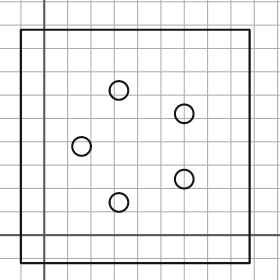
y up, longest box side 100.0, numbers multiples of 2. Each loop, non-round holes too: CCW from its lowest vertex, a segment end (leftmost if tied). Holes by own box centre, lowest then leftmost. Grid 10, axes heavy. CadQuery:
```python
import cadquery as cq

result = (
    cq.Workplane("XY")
    .moveTo(-10.0, -12.0)
    .lineTo(88.0, -12.0)
    .lineTo(88.0, 88.0)
    .lineTo(-10.0, 88.0)
    .close()
    .moveTo(32.0, 14.0)
    .circle(4.0)
    .moveTo(60.0, 24.0)
    .circle(4.0)
    .moveTo(16.0, 38.0)
    .circle(4.0)
    .moveTo(60.0, 52.0)
    .circle(4.0)
    .moveTo(32.0, 62.0)
    .circle(4.0)
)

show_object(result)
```